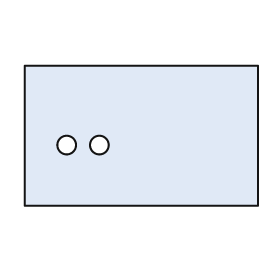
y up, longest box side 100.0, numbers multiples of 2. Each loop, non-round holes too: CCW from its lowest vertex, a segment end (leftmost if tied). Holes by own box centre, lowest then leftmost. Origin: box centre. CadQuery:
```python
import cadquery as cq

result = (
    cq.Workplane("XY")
    .moveTo(-50.0, -30.0)
    .lineTo(50.0, -30.0)
    .lineTo(50.0, 30.0)
    .lineTo(-50.0, 30.0)
    .close()
    .moveTo(-32.0, -4.0)
    .circle(4.0)
    .moveTo(-18.0, -4.0)
    .circle(4.0)
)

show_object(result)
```